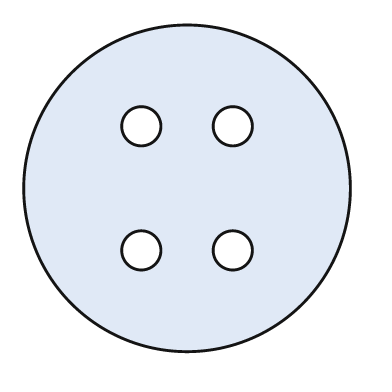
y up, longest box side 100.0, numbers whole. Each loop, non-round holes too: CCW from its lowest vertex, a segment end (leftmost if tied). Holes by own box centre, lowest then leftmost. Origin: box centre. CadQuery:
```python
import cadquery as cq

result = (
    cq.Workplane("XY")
    .moveTo(0.0, 0.0)
    .circle(50.0)
    .moveTo(-14.0, -19.0)
    .circle(6.0)
    .moveTo(14.0, -19.0)
    .circle(6.0)
    .moveTo(-14.0, 19.0)
    .circle(6.0)
    .moveTo(14.0, 19.0)
    .circle(6.0)
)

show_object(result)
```